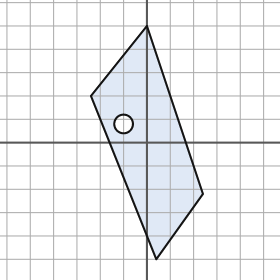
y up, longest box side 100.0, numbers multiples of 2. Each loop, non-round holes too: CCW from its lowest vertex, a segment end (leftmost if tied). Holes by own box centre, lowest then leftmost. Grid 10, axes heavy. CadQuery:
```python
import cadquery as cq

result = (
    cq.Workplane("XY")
    .moveTo(4.0, -50.0)
    .lineTo(24.0, -22.0)
    .lineTo(0.0, 50.0)
    .lineTo(-24.0, 20.0)
    .close()
    .moveTo(-10.0, 8.0)
    .circle(4.0)
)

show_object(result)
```